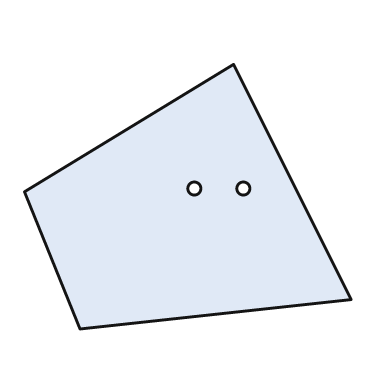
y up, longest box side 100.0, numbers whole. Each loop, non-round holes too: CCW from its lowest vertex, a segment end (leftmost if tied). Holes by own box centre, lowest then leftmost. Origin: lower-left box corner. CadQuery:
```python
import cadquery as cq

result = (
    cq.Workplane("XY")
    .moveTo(17.0, 0.0)
    .lineTo(100.0, 9.0)
    .lineTo(64.0, 81.0)
    .lineTo(0.0, 42.0)
    .close()
    .moveTo(52.0, 43.0)
    .circle(2.0)
    .moveTo(67.0, 43.0)
    .circle(2.0)
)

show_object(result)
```